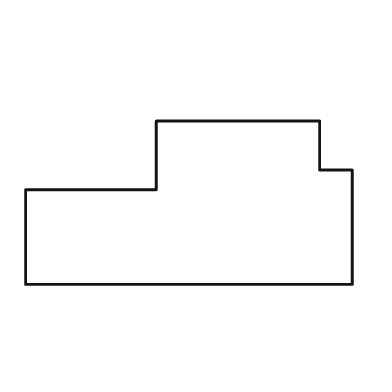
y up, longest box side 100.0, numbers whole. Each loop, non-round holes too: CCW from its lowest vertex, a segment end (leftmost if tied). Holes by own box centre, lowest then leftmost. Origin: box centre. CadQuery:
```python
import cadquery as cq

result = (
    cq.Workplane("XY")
    .moveTo(-50.0, -25.0)
    .lineTo(50.0, -25.0)
    .lineTo(50.0, 10.0)
    .lineTo(40.0, 10.0)
    .lineTo(40.0, 25.0)
    .lineTo(-10.0, 25.0)
    .lineTo(-10.0, 4.0)
    .lineTo(-50.0, 4.0)
    .close()
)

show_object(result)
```